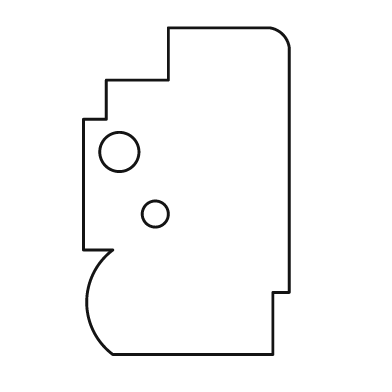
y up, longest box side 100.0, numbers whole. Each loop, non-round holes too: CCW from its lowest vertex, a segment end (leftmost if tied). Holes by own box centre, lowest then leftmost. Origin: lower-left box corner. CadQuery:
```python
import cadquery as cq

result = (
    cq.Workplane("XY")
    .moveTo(9.0, 0.0)
    .lineTo(58.0, 0.0)
    .lineTo(58.0, 19.0)
    .lineTo(63.0, 19.0)
    .lineTo(63.0, 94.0)
    .threePointArc((61.0, 98.0), (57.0, 100.0))
    .lineTo(26.0, 100.0)
    .lineTo(26.0, 84.0)
    .lineTo(7.0, 84.0)
    .lineTo(7.0, 72.0)
    .lineTo(0.0, 72.0)
    .lineTo(0.0, 32.0)
    .lineTo(9.0, 32.0)
    .threePointArc((1.0, 16.0), (9.0, 0.0))
    .close()
    .moveTo(22.0, 43.0)
    .circle(4.0)
    .moveTo(11.0, 62.0)
    .circle(6.0)
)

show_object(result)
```